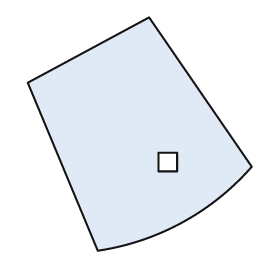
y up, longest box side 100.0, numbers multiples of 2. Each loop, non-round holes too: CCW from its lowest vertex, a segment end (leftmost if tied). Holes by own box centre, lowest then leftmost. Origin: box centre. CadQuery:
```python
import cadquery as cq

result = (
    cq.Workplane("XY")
    .moveTo(-18.0, -50.0)
    .threePointArc((18.0, -38.0), (48.0, -14.0))
    .lineTo(4.0, 50.0)
    .lineTo(-48.0, 22.0)
    .close()
    .moveTo(8.0, -16.0)
    .lineTo(16.0, -16.0)
    .lineTo(16.0, -8.0)
    .lineTo(8.0, -8.0)
    .close()
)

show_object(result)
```